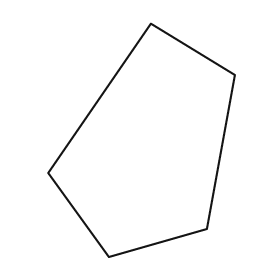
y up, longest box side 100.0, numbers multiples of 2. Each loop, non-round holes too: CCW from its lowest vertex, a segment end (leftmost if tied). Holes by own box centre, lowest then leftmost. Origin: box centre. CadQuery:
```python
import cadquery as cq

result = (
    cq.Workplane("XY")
    .moveTo(-14.0, -50.0)
    .lineTo(28.0, -38.0)
    .lineTo(40.0, 28.0)
    .lineTo(4.0, 50.0)
    .lineTo(-40.0, -14.0)
    .close()
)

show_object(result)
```